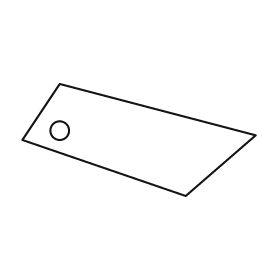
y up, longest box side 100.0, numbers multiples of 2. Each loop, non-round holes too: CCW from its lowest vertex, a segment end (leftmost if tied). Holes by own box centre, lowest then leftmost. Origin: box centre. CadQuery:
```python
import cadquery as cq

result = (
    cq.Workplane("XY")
    .moveTo(20.0, -24.0)
    .lineTo(50.0, 2.0)
    .lineTo(-34.0, 24.0)
    .lineTo(-50.0, 0.0)
    .close()
    .moveTo(-34.0, 4.0)
    .circle(4.0)
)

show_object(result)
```